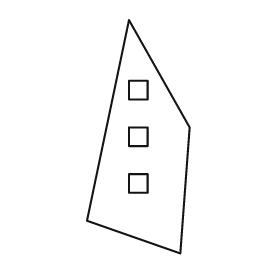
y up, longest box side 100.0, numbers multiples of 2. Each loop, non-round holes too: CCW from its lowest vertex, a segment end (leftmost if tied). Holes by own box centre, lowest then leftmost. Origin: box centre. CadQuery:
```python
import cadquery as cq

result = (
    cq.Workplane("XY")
    .moveTo(18.0, -50.0)
    .lineTo(22.0, 4.0)
    .lineTo(-4.0, 50.0)
    .lineTo(-22.0, -36.0)
    .close()
    .moveTo(-4.0, -24.0)
    .lineTo(4.0, -24.0)
    .lineTo(4.0, -16.0)
    .lineTo(-4.0, -16.0)
    .close()
    .moveTo(-4.0, -4.0)
    .lineTo(4.0, -4.0)
    .lineTo(4.0, 4.0)
    .lineTo(-4.0, 4.0)
    .close()
    .moveTo(-4.0, 16.0)
    .lineTo(4.0, 16.0)
    .lineTo(4.0, 24.0)
    .lineTo(-4.0, 24.0)
    .close()
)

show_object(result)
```